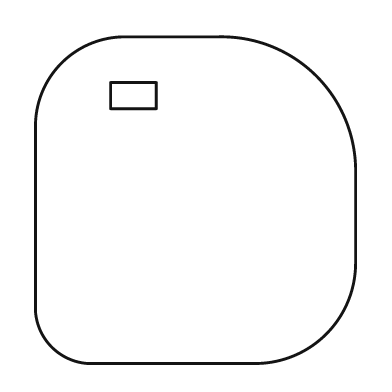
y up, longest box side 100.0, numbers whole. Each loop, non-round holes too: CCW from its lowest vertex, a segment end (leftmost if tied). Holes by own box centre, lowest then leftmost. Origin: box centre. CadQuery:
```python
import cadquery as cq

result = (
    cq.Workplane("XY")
    .moveTo(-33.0, -50.0)
    .lineTo(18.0, -50.0)
    .threePointArc((40.0, -41.0), (49.0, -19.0))
    .lineTo(49.0, 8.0)
    .threePointArc((37.0, 38.0), (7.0, 50.0))
    .lineTo(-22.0, 50.0)
    .threePointArc((-41.0, 42.0), (-49.0, 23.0))
    .lineTo(-49.0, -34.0)
    .threePointArc((-44.0, -45.0), (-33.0, -50.0))
    .close()
    .moveTo(-26.0, 28.0)
    .lineTo(-12.0, 28.0)
    .lineTo(-12.0, 36.0)
    .lineTo(-26.0, 36.0)
    .close()
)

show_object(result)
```